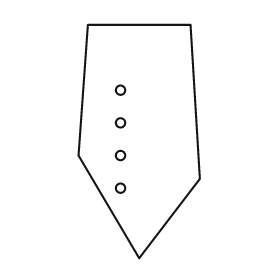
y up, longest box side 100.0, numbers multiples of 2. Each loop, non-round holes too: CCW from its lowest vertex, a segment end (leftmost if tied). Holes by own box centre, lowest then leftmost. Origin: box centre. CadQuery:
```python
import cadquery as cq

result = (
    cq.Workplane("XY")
    .moveTo(0.0, -50.0)
    .lineTo(26.0, -16.0)
    .lineTo(22.0, 50.0)
    .lineTo(-22.0, 50.0)
    .lineTo(-26.0, -6.0)
    .close()
    .moveTo(-8.0, -20.0)
    .circle(2.0)
    .moveTo(-8.0, -6.0)
    .circle(2.0)
    .moveTo(-8.0, 8.0)
    .circle(2.0)
    .moveTo(-8.0, 22.0)
    .circle(2.0)
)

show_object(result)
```